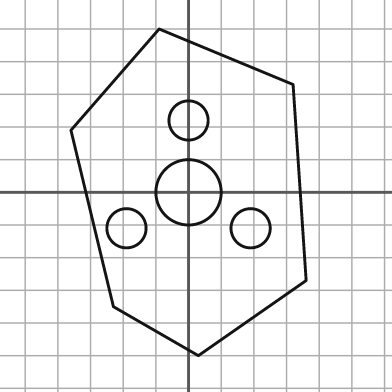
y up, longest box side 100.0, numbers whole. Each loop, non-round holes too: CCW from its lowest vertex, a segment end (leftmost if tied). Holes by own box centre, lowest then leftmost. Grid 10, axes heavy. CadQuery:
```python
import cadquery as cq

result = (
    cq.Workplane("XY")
    .moveTo(3.0, -50.0)
    .lineTo(36.0, -27.0)
    .lineTo(32.0, 33.0)
    .lineTo(-9.0, 50.0)
    .lineTo(-36.0, 19.0)
    .lineTo(-23.0, -35.0)
    .close()
    .moveTo(-19.0, -11.0)
    .circle(6.0)
    .moveTo(19.0, -11.0)
    .circle(6.0)
    .moveTo(0.0, 0.0)
    .circle(10.0)
    .moveTo(0.0, 22.0)
    .circle(6.0)
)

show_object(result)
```